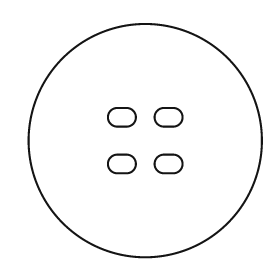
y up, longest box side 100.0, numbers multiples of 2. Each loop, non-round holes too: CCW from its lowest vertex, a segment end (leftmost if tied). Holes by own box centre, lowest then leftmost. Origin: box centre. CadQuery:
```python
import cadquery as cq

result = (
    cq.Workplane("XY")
    .moveTo(0.0, 0.0)
    .circle(50.0)
    .moveTo(-12.0, -14.0)
    .lineTo(-8.0, -14.0)
    .threePointArc((-4.0, -10.0), (-8.0, -6.0))
    .lineTo(-12.0, -6.0)
    .threePointArc((-16.0, -10.0), (-12.0, -14.0))
    .close()
    .moveTo(8.0, -14.0)
    .lineTo(12.0, -14.0)
    .threePointArc((16.0, -10.0), (12.0, -6.0))
    .lineTo(8.0, -6.0)
    .threePointArc((4.0, -10.0), (8.0, -14.0))
    .close()
    .moveTo(-12.0, 6.0)
    .lineTo(-8.0, 6.0)
    .threePointArc((-4.0, 10.0), (-8.0, 14.0))
    .lineTo(-12.0, 14.0)
    .threePointArc((-16.0, 10.0), (-12.0, 6.0))
    .close()
    .moveTo(8.0, 6.0)
    .lineTo(12.0, 6.0)
    .threePointArc((16.0, 10.0), (12.0, 14.0))
    .lineTo(8.0, 14.0)
    .threePointArc((4.0, 10.0), (8.0, 6.0))
    .close()
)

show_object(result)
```